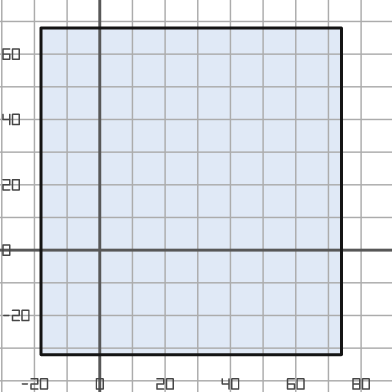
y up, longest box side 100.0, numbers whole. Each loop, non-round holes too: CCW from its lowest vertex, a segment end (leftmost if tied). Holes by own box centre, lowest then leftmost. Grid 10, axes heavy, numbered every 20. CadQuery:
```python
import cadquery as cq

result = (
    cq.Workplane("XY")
    .moveTo(-18.0, -32.0)
    .lineTo(74.0, -32.0)
    .lineTo(74.0, 68.0)
    .lineTo(-18.0, 68.0)
    .close()
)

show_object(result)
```